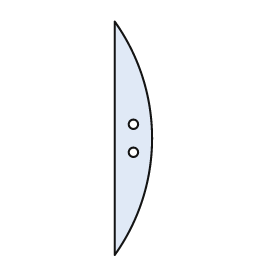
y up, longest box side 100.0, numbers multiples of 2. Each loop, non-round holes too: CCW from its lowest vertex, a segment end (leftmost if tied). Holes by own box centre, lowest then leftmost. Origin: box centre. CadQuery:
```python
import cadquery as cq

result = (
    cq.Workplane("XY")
    .moveTo(-8.0, -50.0)
    .threePointArc((8.0, 0.0), (-8.0, 50.0))
    .close()
    .moveTo(0.0, -6.0)
    .circle(2.0)
    .moveTo(0.0, 6.0)
    .circle(2.0)
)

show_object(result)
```